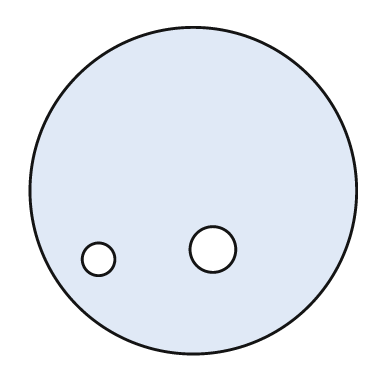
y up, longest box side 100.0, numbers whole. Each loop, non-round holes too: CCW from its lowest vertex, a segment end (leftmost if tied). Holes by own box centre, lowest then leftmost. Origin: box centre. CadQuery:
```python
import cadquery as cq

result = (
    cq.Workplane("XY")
    .moveTo(0.0, 0.0)
    .circle(50.0)
    .moveTo(-29.0, -21.0)
    .circle(5.0)
    .moveTo(6.0, -18.0)
    .circle(7.0)
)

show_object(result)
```